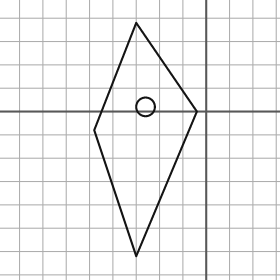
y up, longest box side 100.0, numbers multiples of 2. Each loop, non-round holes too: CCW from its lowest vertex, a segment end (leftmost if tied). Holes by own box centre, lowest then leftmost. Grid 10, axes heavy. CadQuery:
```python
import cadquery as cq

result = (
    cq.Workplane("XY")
    .moveTo(-30.0, -62.0)
    .lineTo(-4.0, 0.0)
    .lineTo(-30.0, 38.0)
    .lineTo(-48.0, -8.0)
    .close()
    .moveTo(-26.0, 2.0)
    .circle(4.0)
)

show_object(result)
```